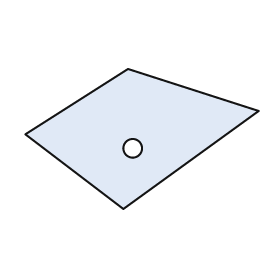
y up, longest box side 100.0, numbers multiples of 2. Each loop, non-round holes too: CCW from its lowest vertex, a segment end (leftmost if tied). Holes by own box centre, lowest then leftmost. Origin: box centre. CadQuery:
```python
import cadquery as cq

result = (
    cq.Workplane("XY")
    .moveTo(-8.0, -30.0)
    .lineTo(50.0, 12.0)
    .lineTo(-6.0, 30.0)
    .lineTo(-50.0, 2.0)
    .close()
    .moveTo(-4.0, -4.0)
    .circle(4.0)
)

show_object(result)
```